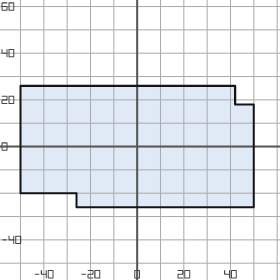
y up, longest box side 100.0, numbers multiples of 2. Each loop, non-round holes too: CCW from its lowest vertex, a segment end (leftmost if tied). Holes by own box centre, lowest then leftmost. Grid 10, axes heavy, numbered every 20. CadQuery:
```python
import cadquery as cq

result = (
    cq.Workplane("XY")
    .moveTo(-26.0, -26.0)
    .lineTo(50.0, -26.0)
    .lineTo(50.0, 18.0)
    .lineTo(42.0, 18.0)
    .lineTo(42.0, 26.0)
    .lineTo(-50.0, 26.0)
    .lineTo(-50.0, -20.0)
    .lineTo(-26.0, -20.0)
    .close()
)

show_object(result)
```